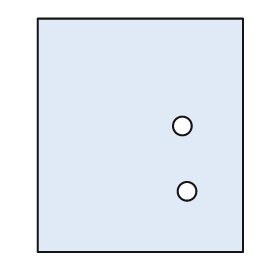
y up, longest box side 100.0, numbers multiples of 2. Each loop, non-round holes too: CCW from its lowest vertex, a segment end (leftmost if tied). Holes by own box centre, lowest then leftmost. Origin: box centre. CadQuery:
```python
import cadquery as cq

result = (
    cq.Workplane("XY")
    .moveTo(-44.0, -50.0)
    .lineTo(44.0, -50.0)
    .lineTo(44.0, 50.0)
    .lineTo(-44.0, 50.0)
    .close()
    .moveTo(20.0, -24.0)
    .circle(4.0)
    .moveTo(18.0, 4.0)
    .circle(4.0)
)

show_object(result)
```